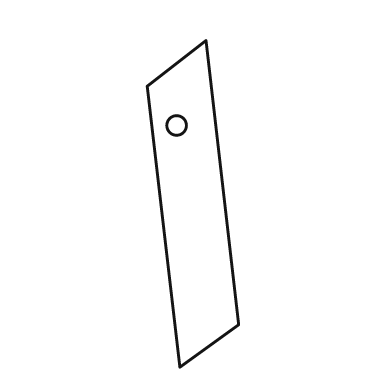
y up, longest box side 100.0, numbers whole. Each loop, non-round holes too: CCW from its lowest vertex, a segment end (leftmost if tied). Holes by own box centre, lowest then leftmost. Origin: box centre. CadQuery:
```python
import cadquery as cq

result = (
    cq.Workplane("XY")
    .moveTo(-4.0, -50.0)
    .lineTo(14.0, -37.0)
    .lineTo(4.0, 50.0)
    .lineTo(-14.0, 36.0)
    .close()
    .moveTo(-5.0, 24.0)
    .circle(3.0)
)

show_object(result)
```